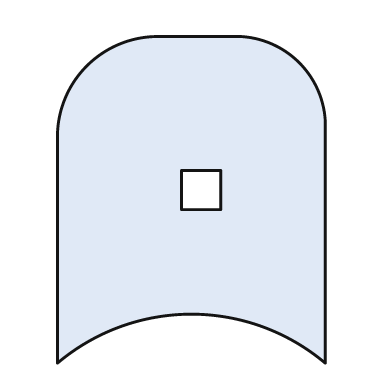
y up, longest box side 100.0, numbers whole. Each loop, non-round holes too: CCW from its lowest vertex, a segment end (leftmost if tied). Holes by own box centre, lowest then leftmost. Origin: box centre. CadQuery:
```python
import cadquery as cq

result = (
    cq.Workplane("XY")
    .moveTo(-41.0, -50.0)
    .threePointArc((0.0, -35.0), (41.0, -50.0))
    .lineTo(41.0, 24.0)
    .threePointArc((33.0, 42.0), (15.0, 50.0))
    .lineTo(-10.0, 50.0)
    .threePointArc((-32.0, 41.0), (-41.0, 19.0))
    .close()
    .moveTo(-3.0, -3.0)
    .lineTo(9.0, -3.0)
    .lineTo(9.0, 9.0)
    .lineTo(-3.0, 9.0)
    .close()
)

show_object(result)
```